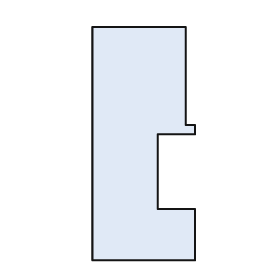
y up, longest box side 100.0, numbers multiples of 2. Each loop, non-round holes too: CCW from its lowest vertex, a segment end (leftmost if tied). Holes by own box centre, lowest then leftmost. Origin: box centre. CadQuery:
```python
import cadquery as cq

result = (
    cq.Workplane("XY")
    .moveTo(-22.0, -50.0)
    .lineTo(22.0, -50.0)
    .lineTo(22.0, -28.0)
    .lineTo(6.0, -28.0)
    .lineTo(6.0, 4.0)
    .lineTo(22.0, 4.0)
    .lineTo(22.0, 8.0)
    .lineTo(18.0, 8.0)
    .lineTo(18.0, 50.0)
    .lineTo(-22.0, 50.0)
    .close()
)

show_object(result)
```